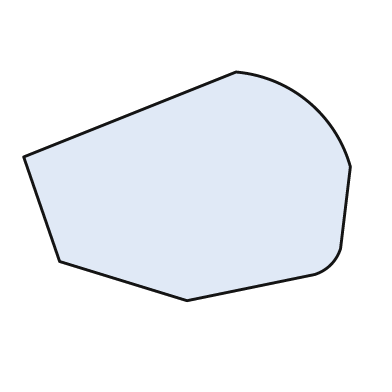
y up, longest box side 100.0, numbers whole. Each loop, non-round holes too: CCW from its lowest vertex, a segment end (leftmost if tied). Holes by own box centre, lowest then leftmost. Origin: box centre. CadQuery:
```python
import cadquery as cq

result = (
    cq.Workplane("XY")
    .moveTo(0.0, -35.0)
    .lineTo(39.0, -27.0)
    .threePointArc((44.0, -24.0), (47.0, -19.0))
    .lineTo(50.0, 6.0)
    .threePointArc((37.0, 26.0), (15.0, 35.0))
    .lineTo(-50.0, 9.0)
    .lineTo(-39.0, -23.0)
    .close()
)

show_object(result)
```